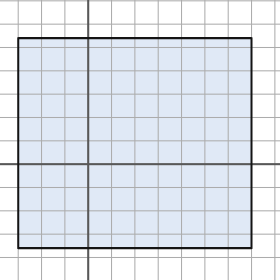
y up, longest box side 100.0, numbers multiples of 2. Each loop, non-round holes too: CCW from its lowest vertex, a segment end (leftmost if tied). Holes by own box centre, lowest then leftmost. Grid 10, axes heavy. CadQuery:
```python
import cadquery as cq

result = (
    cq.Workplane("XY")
    .moveTo(-30.0, -36.0)
    .lineTo(70.0, -36.0)
    .lineTo(70.0, 54.0)
    .lineTo(-30.0, 54.0)
    .close()
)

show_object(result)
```